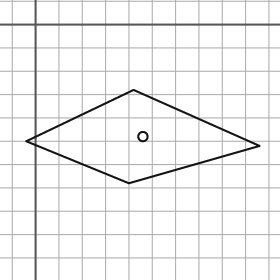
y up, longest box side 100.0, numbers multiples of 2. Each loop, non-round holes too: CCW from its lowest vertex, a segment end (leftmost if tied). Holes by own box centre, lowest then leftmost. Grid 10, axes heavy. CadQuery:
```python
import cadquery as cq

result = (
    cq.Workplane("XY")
    .moveTo(40.0, -68.0)
    .lineTo(96.0, -52.0)
    .lineTo(42.0, -28.0)
    .lineTo(-4.0, -50.0)
    .close()
    .moveTo(46.0, -48.0)
    .circle(2.0)
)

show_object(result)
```